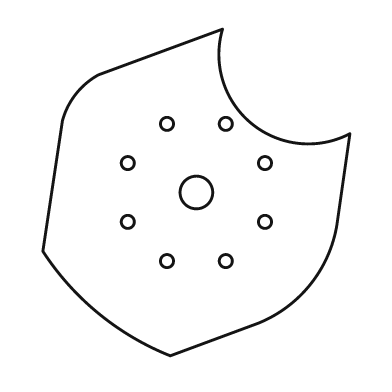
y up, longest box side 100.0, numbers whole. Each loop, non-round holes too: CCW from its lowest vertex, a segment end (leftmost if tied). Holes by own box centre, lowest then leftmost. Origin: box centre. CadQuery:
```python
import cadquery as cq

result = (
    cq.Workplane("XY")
    .moveTo(-8.0, -50.0)
    .lineTo(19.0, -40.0)
    .threePointArc((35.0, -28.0), (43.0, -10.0))
    .lineTo(47.0, 18.0)
    .threePointArc((17.0, 21.0), (8.0, 50.0))
    .lineTo(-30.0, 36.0)
    .threePointArc((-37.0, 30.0), (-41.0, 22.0))
    .lineTo(-47.0, -18.0)
    .threePointArc((-30.0, -37.0), (-8.0, -50.0))
    .close()
    .moveTo(-9.0, -21.0)
    .circle(2.0)
    .moveTo(9.0, -21.0)
    .circle(2.0)
    .moveTo(-21.0, -9.0)
    .circle(2.0)
    .moveTo(21.0, -9.0)
    .circle(2.0)
    .moveTo(0.0, 0.0)
    .circle(5.0)
    .moveTo(-21.0, 9.0)
    .circle(2.0)
    .moveTo(21.0, 9.0)
    .circle(2.0)
    .moveTo(-9.0, 21.0)
    .circle(2.0)
    .moveTo(9.0, 21.0)
    .circle(2.0)
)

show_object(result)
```